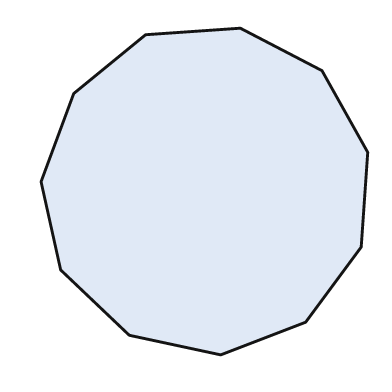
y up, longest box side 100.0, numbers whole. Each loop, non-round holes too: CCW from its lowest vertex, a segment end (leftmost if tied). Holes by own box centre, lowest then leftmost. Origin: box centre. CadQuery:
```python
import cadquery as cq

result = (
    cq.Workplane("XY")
    .moveTo(5.0, -50.0)
    .lineTo(31.0, -40.0)
    .lineTo(48.0, -17.0)
    .lineTo(50.0, 12.0)
    .lineTo(36.0, 37.0)
    .lineTo(11.0, 50.0)
    .lineTo(-18.0, 48.0)
    .lineTo(-40.0, 30.0)
    .lineTo(-50.0, 3.0)
    .lineTo(-44.0, -24.0)
    .lineTo(-23.0, -44.0)
    .close()
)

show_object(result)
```